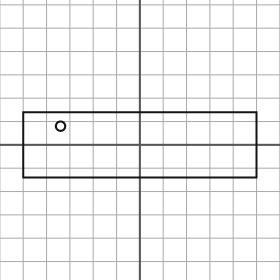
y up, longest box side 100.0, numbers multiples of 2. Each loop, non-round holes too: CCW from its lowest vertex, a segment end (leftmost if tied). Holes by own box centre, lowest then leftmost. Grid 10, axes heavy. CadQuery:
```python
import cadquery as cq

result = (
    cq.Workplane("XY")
    .moveTo(-50.0, -14.0)
    .lineTo(50.0, -14.0)
    .lineTo(50.0, 14.0)
    .lineTo(-50.0, 14.0)
    .close()
    .moveTo(-34.0, 8.0)
    .circle(2.0)
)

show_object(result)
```